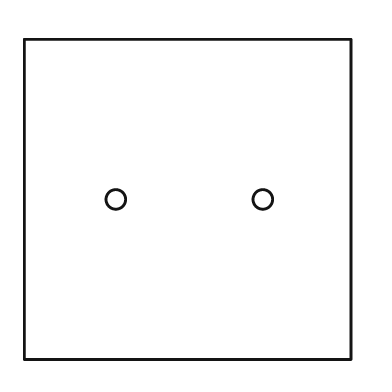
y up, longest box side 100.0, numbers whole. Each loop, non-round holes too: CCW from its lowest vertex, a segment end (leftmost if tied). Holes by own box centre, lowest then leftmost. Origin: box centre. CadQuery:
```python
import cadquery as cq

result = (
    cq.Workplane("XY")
    .moveTo(-50.0, -49.0)
    .lineTo(50.0, -49.0)
    .lineTo(50.0, 49.0)
    .lineTo(-50.0, 49.0)
    .close()
    .moveTo(-22.0, 0.0)
    .circle(3.0)
    .moveTo(23.0, 0.0)
    .circle(3.0)
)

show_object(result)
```